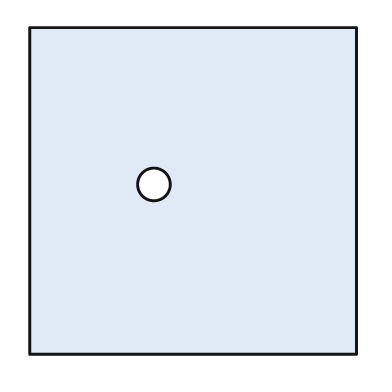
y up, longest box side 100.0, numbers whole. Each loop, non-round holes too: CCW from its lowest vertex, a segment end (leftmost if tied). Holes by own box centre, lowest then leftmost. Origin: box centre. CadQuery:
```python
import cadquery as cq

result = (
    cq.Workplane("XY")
    .moveTo(-50.0, -50.0)
    .lineTo(50.0, -50.0)
    .lineTo(50.0, 50.0)
    .lineTo(-50.0, 50.0)
    .close()
    .moveTo(-12.0, 2.0)
    .circle(5.0)
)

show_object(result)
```